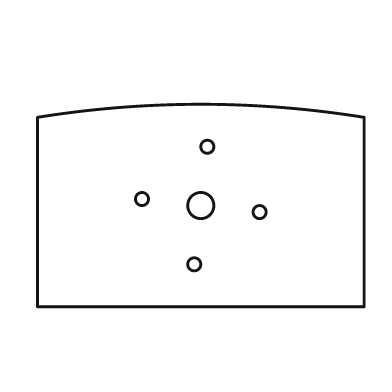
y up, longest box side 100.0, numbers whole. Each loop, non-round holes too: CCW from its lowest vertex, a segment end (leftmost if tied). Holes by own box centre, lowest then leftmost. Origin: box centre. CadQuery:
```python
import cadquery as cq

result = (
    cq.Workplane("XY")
    .moveTo(-50.0, -31.0)
    .lineTo(50.0, -31.0)
    .lineTo(50.0, 27.0)
    .threePointArc((0.0, 31.0), (-50.0, 27.0))
    .close()
    .moveTo(-2.0, -18.0)
    .circle(2.0)
    .moveTo(18.0, -2.0)
    .circle(2.0)
    .moveTo(0.0, 0.0)
    .circle(4.0)
    .moveTo(-18.0, 2.0)
    .circle(2.0)
    .moveTo(2.0, 18.0)
    .circle(2.0)
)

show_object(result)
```